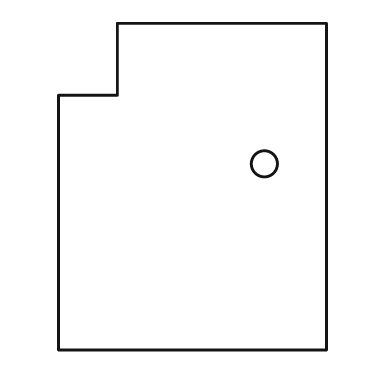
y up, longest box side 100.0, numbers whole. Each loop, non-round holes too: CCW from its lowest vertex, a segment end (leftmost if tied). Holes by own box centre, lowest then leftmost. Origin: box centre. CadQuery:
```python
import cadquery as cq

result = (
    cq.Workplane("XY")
    .moveTo(-41.0, -50.0)
    .lineTo(41.0, -50.0)
    .lineTo(41.0, 50.0)
    .lineTo(-23.0, 50.0)
    .lineTo(-23.0, 28.0)
    .lineTo(-41.0, 28.0)
    .close()
    .moveTo(22.0, 7.0)
    .circle(4.0)
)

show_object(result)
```